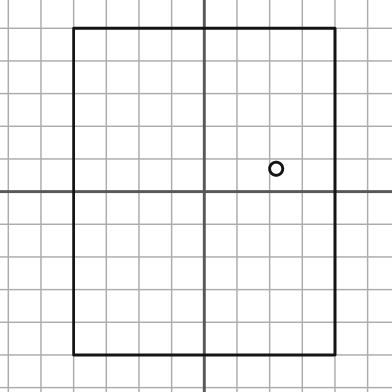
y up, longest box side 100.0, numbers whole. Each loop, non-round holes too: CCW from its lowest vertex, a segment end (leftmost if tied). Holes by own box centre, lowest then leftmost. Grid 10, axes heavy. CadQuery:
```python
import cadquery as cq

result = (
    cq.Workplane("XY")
    .moveTo(-40.0, -50.0)
    .lineTo(40.0, -50.0)
    .lineTo(40.0, 50.0)
    .lineTo(-40.0, 50.0)
    .close()
    .moveTo(22.0, 7.0)
    .circle(2.0)
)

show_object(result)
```